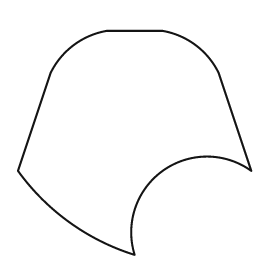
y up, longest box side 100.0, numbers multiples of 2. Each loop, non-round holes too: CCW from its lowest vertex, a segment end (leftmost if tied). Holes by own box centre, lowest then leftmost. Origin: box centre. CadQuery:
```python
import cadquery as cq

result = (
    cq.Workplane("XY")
    .moveTo(0.0, -48.0)
    .threePointArc((12.0, -12.0), (50.0, -12.0))
    .lineTo(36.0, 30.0)
    .threePointArc((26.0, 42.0), (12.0, 48.0))
    .lineTo(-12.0, 48.0)
    .threePointArc((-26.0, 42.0), (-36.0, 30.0))
    .lineTo(-50.0, -12.0)
    .threePointArc((-28.0, -34.0), (0.0, -48.0))
    .close()
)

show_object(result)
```